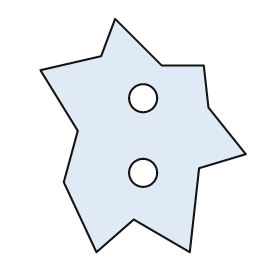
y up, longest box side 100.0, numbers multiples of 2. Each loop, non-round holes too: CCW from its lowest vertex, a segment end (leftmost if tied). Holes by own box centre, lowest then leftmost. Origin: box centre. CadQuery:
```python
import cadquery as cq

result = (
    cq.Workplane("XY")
    .moveTo(-20.0, -50.0)
    .lineTo(-4.0, -36.0)
    .lineTo(20.0, -50.0)
    .lineTo(24.0, -14.0)
    .lineTo(44.0, -8.0)
    .lineTo(28.0, 12.0)
    .lineTo(26.0, 30.0)
    .lineTo(8.0, 30.0)
    .lineTo(-12.0, 50.0)
    .lineTo(-18.0, 34.0)
    .lineTo(-44.0, 28.0)
    .lineTo(-28.0, 2.0)
    .lineTo(-34.0, -20.0)
    .close()
    .moveTo(0.0, -16.0)
    .circle(6.0)
    .moveTo(0.0, 16.0)
    .circle(6.0)
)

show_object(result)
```